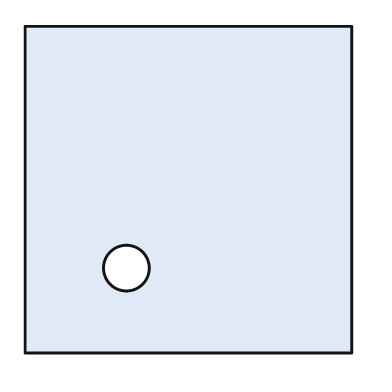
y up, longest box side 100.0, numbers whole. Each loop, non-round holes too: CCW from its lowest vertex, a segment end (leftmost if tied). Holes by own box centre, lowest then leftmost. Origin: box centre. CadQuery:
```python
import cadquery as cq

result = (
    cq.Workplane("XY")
    .moveTo(-50.0, -50.0)
    .lineTo(50.0, -50.0)
    .lineTo(50.0, 50.0)
    .lineTo(-50.0, 50.0)
    .close()
    .moveTo(-19.0, -24.0)
    .circle(7.0)
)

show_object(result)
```